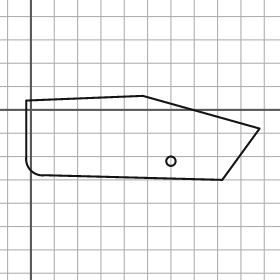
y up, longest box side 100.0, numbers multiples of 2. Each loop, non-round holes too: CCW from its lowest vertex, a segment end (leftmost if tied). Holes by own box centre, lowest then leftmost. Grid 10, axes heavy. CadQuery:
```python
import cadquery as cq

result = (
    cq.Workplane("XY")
    .moveTo(82.0, -30.0)
    .lineTo(98.0, -8.0)
    .lineTo(48.0, 6.0)
    .lineTo(-2.0, 4.0)
    .lineTo(-2.0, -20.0)
    .threePointArc((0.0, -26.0), (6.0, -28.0))
    .close()
    .moveTo(60.0, -22.0)
    .circle(2.0)
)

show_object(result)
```